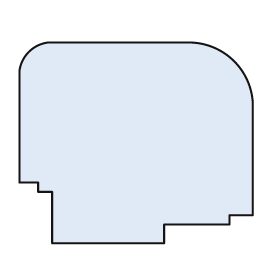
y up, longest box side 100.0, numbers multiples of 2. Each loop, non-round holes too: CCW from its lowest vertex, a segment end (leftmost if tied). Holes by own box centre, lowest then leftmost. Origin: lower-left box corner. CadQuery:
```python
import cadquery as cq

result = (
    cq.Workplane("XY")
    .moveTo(14.0, 0.0)
    .lineTo(62.0, 0.0)
    .lineTo(62.0, 8.0)
    .lineTo(90.0, 8.0)
    .lineTo(90.0, 12.0)
    .lineTo(100.0, 12.0)
    .lineTo(100.0, 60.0)
    .threePointArc((92.0, 78.0), (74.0, 86.0))
    .lineTo(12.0, 86.0)
    .threePointArc((4.0, 82.0), (0.0, 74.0))
    .lineTo(0.0, 26.0)
    .lineTo(8.0, 26.0)
    .lineTo(8.0, 22.0)
    .lineTo(14.0, 22.0)
    .close()
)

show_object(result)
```